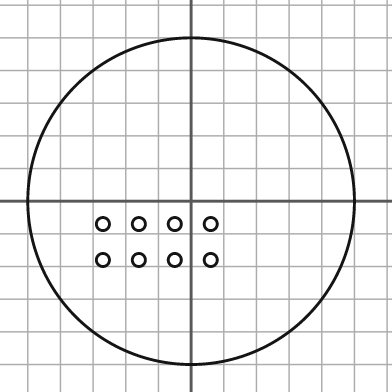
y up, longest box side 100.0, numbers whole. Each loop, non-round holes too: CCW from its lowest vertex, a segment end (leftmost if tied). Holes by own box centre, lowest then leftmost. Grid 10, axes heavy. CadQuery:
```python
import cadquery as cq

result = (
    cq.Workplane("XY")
    .moveTo(0.0, 0.0)
    .circle(50.0)
    .moveTo(-27.0, -18.0)
    .circle(2.0)
    .moveTo(-16.0, -18.0)
    .circle(2.0)
    .moveTo(-5.0, -18.0)
    .circle(2.0)
    .moveTo(6.0, -18.0)
    .circle(2.0)
    .moveTo(-27.0, -7.0)
    .circle(2.0)
    .moveTo(-16.0, -7.0)
    .circle(2.0)
    .moveTo(-5.0, -7.0)
    .circle(2.0)
    .moveTo(6.0, -7.0)
    .circle(2.0)
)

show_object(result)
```